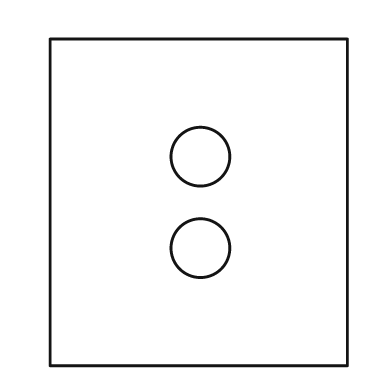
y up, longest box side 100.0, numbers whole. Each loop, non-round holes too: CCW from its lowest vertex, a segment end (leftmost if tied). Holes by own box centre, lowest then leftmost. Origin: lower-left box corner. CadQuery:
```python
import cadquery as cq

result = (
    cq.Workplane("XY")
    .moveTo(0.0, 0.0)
    .lineTo(91.0, 0.0)
    .lineTo(91.0, 100.0)
    .lineTo(0.0, 100.0)
    .close()
    .moveTo(46.0, 36.0)
    .circle(9.0)
    .moveTo(46.0, 64.0)
    .circle(9.0)
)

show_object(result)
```